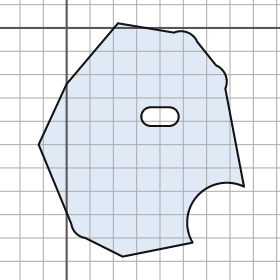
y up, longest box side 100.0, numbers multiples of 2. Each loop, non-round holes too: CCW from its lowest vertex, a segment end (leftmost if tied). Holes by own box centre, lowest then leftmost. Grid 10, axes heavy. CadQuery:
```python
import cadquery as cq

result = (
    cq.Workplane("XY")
    .moveTo(24.0, -98.0)
    .lineTo(54.0, -92.0)
    .threePointArc((56.0, -72.0), (76.0, -68.0))
    .lineTo(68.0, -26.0)
    .threePointArc((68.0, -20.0), (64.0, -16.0))
    .lineTo(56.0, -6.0)
    .threePointArc((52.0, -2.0), (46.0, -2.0))
    .lineTo(22.0, 2.0)
    .lineTo(0.0, -24.0)
    .lineTo(-12.0, -50.0)
    .lineTo(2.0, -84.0)
    .threePointArc((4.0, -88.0), (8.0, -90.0))
    .close()
    .moveTo(36.0, -42.0)
    .lineTo(44.0, -42.0)
    .threePointArc((48.0, -38.0), (44.0, -34.0))
    .lineTo(36.0, -34.0)
    .threePointArc((32.0, -38.0), (36.0, -42.0))
    .close()
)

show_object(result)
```